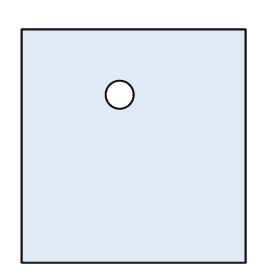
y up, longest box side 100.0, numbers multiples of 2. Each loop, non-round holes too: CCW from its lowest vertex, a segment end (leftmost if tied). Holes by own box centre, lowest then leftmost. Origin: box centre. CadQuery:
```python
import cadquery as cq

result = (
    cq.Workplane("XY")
    .moveTo(-48.0, -50.0)
    .lineTo(48.0, -50.0)
    .lineTo(48.0, 50.0)
    .lineTo(-48.0, 50.0)
    .close()
    .moveTo(-6.0, 22.0)
    .circle(6.0)
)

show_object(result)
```